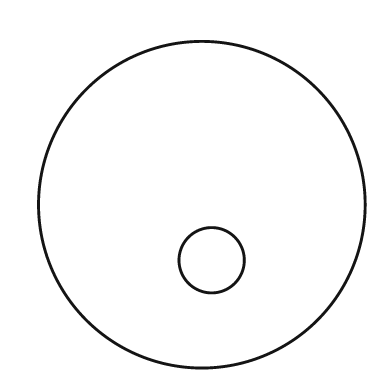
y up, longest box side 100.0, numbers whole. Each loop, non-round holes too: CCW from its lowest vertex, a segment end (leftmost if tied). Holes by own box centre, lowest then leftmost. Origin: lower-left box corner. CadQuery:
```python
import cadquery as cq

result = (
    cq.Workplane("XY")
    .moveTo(50.0, 50.0)
    .circle(50.0)
    .moveTo(53.0, 33.0)
    .circle(10.0)
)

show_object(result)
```